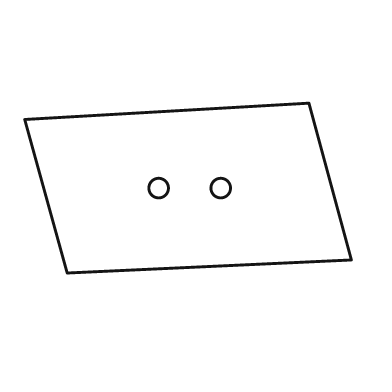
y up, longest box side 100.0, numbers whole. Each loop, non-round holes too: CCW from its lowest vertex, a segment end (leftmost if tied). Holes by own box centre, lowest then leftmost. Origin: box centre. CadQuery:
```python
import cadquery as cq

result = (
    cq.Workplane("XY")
    .moveTo(-37.0, -26.0)
    .lineTo(50.0, -22.0)
    .lineTo(37.0, 26.0)
    .lineTo(-50.0, 21.0)
    .close()
    .moveTo(-9.0, 0.0)
    .circle(3.0)
    .moveTo(10.0, 0.0)
    .circle(3.0)
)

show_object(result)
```